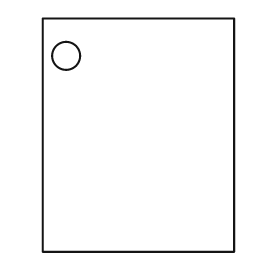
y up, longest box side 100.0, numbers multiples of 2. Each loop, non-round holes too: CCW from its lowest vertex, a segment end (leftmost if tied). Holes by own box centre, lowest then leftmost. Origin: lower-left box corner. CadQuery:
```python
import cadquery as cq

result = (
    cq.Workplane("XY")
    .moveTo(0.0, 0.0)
    .lineTo(82.0, 0.0)
    .lineTo(82.0, 100.0)
    .lineTo(0.0, 100.0)
    .close()
    .moveTo(10.0, 84.0)
    .circle(6.0)
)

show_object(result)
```